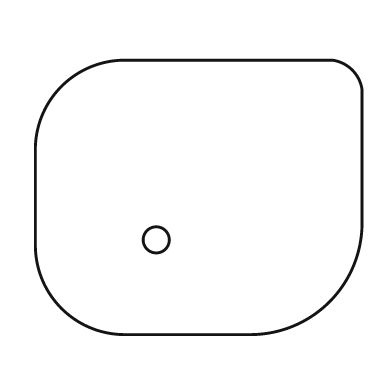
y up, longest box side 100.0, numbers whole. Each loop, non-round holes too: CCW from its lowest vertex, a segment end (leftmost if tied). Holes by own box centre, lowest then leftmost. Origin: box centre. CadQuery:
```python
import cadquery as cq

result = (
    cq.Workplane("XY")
    .moveTo(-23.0, -42.0)
    .lineTo(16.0, -42.0)
    .threePointArc((40.0, -32.0), (50.0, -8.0))
    .lineTo(50.0, 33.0)
    .threePointArc((47.0, 39.0), (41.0, 42.0))
    .lineTo(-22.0, 42.0)
    .threePointArc((-42.0, 34.0), (-50.0, 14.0))
    .lineTo(-50.0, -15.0)
    .threePointArc((-42.0, -34.0), (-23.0, -42.0))
    .close()
    .moveTo(-13.0, -13.0)
    .circle(4.0)
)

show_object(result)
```